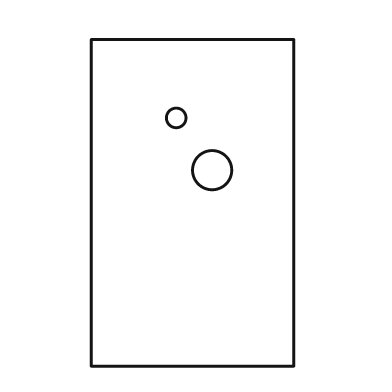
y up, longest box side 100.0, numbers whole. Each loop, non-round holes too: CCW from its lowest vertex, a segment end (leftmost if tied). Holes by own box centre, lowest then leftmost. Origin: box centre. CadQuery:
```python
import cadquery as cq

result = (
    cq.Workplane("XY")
    .moveTo(-31.0, -50.0)
    .lineTo(31.0, -50.0)
    .lineTo(31.0, 50.0)
    .lineTo(-31.0, 50.0)
    .close()
    .moveTo(6.0, 10.0)
    .circle(6.0)
    .moveTo(-5.0, 26.0)
    .circle(3.0)
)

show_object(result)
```